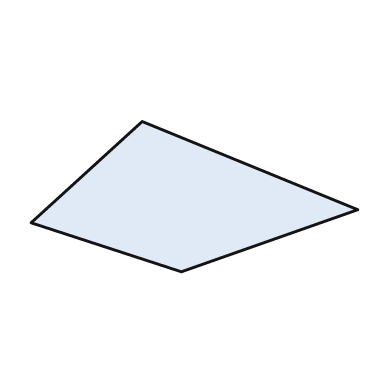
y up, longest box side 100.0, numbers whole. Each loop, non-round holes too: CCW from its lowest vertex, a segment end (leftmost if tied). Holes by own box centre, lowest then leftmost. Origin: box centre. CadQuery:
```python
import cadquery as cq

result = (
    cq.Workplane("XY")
    .moveTo(-4.0, -23.0)
    .lineTo(50.0, -4.0)
    .lineTo(-16.0, 23.0)
    .lineTo(-50.0, -8.0)
    .close()
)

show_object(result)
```